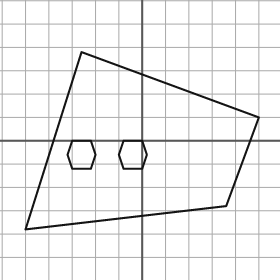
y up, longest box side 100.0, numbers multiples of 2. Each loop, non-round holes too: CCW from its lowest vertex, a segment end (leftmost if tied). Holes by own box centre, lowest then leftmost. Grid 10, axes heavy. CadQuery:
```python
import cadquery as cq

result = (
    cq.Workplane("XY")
    .moveTo(-50.0, -38.0)
    .lineTo(36.0, -28.0)
    .lineTo(50.0, 10.0)
    .lineTo(-26.0, 38.0)
    .close()
    .moveTo(-30.0, -12.0)
    .lineTo(-22.0, -12.0)
    .lineTo(-20.0, -6.0)
    .lineTo(-22.0, 0.0)
    .lineTo(-30.0, 0.0)
    .lineTo(-32.0, -6.0)
    .close()
    .moveTo(-8.0, -12.0)
    .lineTo(0.0, -12.0)
    .lineTo(2.0, -6.0)
    .lineTo(0.0, 0.0)
    .lineTo(-8.0, 0.0)
    .lineTo(-10.0, -6.0)
    .close()
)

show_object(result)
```